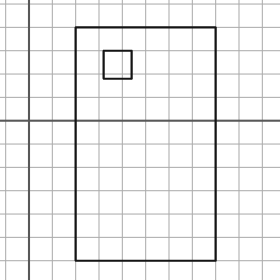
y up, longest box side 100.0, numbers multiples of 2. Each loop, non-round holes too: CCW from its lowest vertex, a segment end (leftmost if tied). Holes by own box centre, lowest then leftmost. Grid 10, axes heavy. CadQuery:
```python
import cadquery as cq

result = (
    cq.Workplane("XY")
    .moveTo(20.0, -60.0)
    .lineTo(80.0, -60.0)
    .lineTo(80.0, 40.0)
    .lineTo(20.0, 40.0)
    .close()
    .moveTo(32.0, 18.0)
    .lineTo(44.0, 18.0)
    .lineTo(44.0, 30.0)
    .lineTo(32.0, 30.0)
    .close()
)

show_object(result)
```